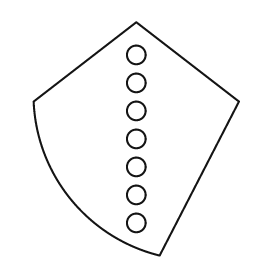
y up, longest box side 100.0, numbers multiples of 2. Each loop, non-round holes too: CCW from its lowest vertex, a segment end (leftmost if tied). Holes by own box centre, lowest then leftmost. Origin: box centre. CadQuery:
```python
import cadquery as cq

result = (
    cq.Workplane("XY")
    .moveTo(10.0, -50.0)
    .lineTo(44.0, 16.0)
    .lineTo(0.0, 50.0)
    .lineTo(-44.0, 16.0)
    .threePointArc((-28.0, -26.0), (10.0, -50.0))
    .close()
    .moveTo(0.0, -36.0)
    .circle(4.0)
    .moveTo(0.0, -24.0)
    .circle(4.0)
    .moveTo(0.0, -12.0)
    .circle(4.0)
    .moveTo(0.0, 0.0)
    .circle(4.0)
    .moveTo(0.0, 12.0)
    .circle(4.0)
    .moveTo(0.0, 24.0)
    .circle(4.0)
    .moveTo(0.0, 36.0)
    .circle(4.0)
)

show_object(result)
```